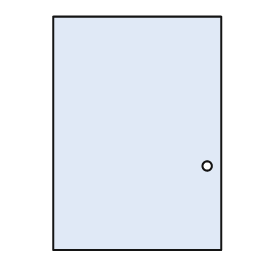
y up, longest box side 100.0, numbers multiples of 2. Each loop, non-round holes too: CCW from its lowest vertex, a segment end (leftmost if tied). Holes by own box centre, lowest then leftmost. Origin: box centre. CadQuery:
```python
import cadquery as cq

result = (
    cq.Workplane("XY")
    .moveTo(-36.0, -50.0)
    .lineTo(36.0, -50.0)
    .lineTo(36.0, 50.0)
    .lineTo(-36.0, 50.0)
    .close()
    .moveTo(30.0, -14.0)
    .circle(2.0)
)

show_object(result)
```